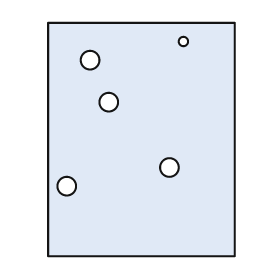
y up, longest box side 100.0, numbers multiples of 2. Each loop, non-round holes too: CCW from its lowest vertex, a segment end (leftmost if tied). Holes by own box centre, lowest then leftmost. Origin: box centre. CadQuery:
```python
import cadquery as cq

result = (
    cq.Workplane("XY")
    .moveTo(-40.0, -50.0)
    .lineTo(40.0, -50.0)
    .lineTo(40.0, 50.0)
    .lineTo(-40.0, 50.0)
    .close()
    .moveTo(-32.0, -20.0)
    .circle(4.0)
    .moveTo(12.0, -12.0)
    .circle(4.0)
    .moveTo(-14.0, 16.0)
    .circle(4.0)
    .moveTo(-22.0, 34.0)
    .circle(4.0)
    .moveTo(18.0, 42.0)
    .circle(2.0)
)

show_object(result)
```